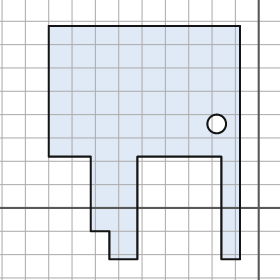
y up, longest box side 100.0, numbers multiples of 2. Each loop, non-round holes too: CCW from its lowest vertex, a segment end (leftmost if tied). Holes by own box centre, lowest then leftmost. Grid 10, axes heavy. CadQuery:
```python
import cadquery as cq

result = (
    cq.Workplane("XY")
    .moveTo(-64.0, -22.0)
    .lineTo(-52.0, -22.0)
    .lineTo(-52.0, 22.0)
    .lineTo(-16.0, 22.0)
    .lineTo(-16.0, -22.0)
    .lineTo(-8.0, -22.0)
    .lineTo(-8.0, 78.0)
    .lineTo(-90.0, 78.0)
    .lineTo(-90.0, 22.0)
    .lineTo(-72.0, 22.0)
    .lineTo(-72.0, -10.0)
    .lineTo(-64.0, -10.0)
    .close()
    .moveTo(-18.0, 36.0)
    .circle(4.0)
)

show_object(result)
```